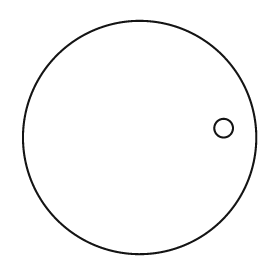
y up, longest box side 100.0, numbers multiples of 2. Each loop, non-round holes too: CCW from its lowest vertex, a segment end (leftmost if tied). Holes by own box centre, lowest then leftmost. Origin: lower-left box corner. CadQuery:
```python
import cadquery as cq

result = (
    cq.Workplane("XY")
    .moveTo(50.0, 50.0)
    .circle(50.0)
    .moveTo(86.0, 54.0)
    .circle(4.0)
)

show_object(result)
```